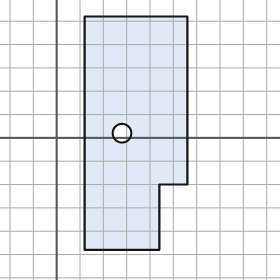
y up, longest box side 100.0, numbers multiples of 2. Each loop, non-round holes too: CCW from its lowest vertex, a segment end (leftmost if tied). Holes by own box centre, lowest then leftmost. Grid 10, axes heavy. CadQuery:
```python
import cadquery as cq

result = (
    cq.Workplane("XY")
    .moveTo(12.0, -48.0)
    .lineTo(44.0, -48.0)
    .lineTo(44.0, -20.0)
    .lineTo(56.0, -20.0)
    .lineTo(56.0, 52.0)
    .lineTo(12.0, 52.0)
    .close()
    .moveTo(28.0, 2.0)
    .circle(4.0)
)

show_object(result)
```